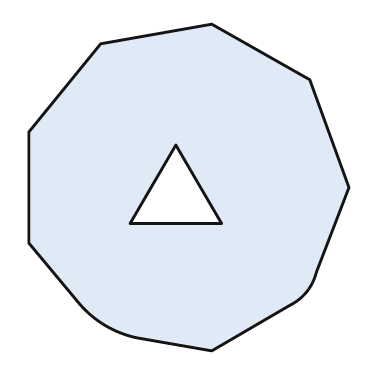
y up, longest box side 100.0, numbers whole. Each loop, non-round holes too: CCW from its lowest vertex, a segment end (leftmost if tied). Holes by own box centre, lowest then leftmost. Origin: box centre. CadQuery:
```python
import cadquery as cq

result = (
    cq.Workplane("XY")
    .moveTo(7.0, -50.0)
    .lineTo(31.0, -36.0)
    .threePointArc((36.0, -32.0), (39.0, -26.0))
    .lineTo(49.0, 0.0)
    .lineTo(37.0, 33.0)
    .lineTo(7.0, 50.0)
    .lineTo(-27.0, 44.0)
    .lineTo(-49.0, 17.0)
    .lineTo(-49.0, -17.0)
    .lineTo(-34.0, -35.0)
    .threePointArc((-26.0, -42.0), (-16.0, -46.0))
    .close()
    .moveTo(-18.0, -11.0)
    .lineTo(10.0, -11.0)
    .lineTo(-4.0, 13.0)
    .close()
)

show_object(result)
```